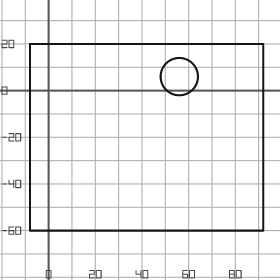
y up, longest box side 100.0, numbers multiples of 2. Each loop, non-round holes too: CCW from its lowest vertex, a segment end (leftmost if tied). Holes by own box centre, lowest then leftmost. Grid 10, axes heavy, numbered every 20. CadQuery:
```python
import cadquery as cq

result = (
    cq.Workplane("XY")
    .moveTo(-8.0, -60.0)
    .lineTo(92.0, -60.0)
    .lineTo(92.0, 20.0)
    .lineTo(-8.0, 20.0)
    .close()
    .moveTo(56.0, 6.0)
    .circle(8.0)
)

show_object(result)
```